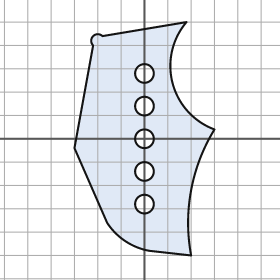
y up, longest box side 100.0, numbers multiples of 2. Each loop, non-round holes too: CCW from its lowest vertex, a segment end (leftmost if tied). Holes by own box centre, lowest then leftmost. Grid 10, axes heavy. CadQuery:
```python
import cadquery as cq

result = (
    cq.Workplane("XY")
    .moveTo(20.0, -50.0)
    .threePointArc((20.0, -22.0), (30.0, 4.0))
    .threePointArc((12.0, 24.0), (18.0, 50.0))
    .lineTo(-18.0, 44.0)
    .threePointArc((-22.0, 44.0), (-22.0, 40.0))
    .lineTo(-30.0, -4.0)
    .lineTo(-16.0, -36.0)
    .threePointArc((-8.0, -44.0), (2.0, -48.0))
    .close()
    .moveTo(0.0, -28.0)
    .circle(4.0)
    .moveTo(0.0, -14.0)
    .circle(4.0)
    .moveTo(0.0, 0.0)
    .circle(4.0)
    .moveTo(0.0, 14.0)
    .circle(4.0)
    .moveTo(0.0, 28.0)
    .circle(4.0)
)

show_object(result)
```